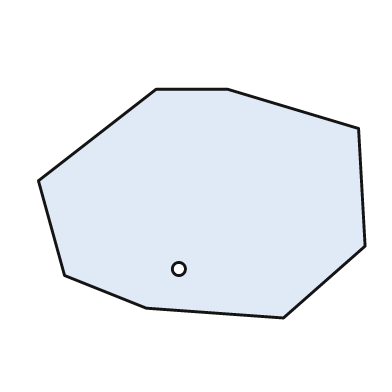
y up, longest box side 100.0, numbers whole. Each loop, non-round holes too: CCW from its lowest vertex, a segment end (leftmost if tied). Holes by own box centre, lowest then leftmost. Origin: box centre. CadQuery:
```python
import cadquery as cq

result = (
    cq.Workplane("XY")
    .moveTo(25.0, -35.0)
    .lineTo(50.0, -13.0)
    .lineTo(48.0, 23.0)
    .lineTo(8.0, 35.0)
    .lineTo(-14.0, 35.0)
    .lineTo(-50.0, 7.0)
    .lineTo(-42.0, -22.0)
    .lineTo(-17.0, -32.0)
    .close()
    .moveTo(-7.0, -20.0)
    .circle(2.0)
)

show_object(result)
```